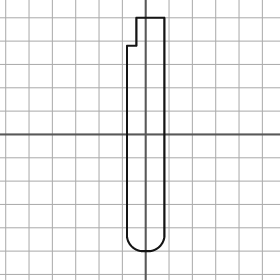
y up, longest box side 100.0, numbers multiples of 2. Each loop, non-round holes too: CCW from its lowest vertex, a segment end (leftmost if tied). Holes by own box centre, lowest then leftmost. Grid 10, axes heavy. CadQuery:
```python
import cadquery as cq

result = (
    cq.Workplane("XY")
    .moveTo(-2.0, -50.0)
    .lineTo(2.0, -50.0)
    .threePointArc((6.0, -48.0), (8.0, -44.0))
    .lineTo(8.0, 50.0)
    .lineTo(-4.0, 50.0)
    .lineTo(-4.0, 38.0)
    .lineTo(-8.0, 38.0)
    .lineTo(-8.0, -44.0)
    .threePointArc((-6.0, -48.0), (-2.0, -50.0))
    .close()
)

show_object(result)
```